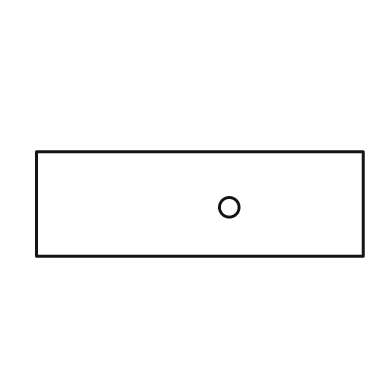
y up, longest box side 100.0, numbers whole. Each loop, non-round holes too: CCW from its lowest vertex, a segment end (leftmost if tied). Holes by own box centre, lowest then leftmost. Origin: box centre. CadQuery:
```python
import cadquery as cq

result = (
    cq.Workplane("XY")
    .moveTo(-50.0, -16.0)
    .lineTo(50.0, -16.0)
    .lineTo(50.0, 16.0)
    .lineTo(-50.0, 16.0)
    .close()
    .moveTo(9.0, -1.0)
    .circle(3.0)
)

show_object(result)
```